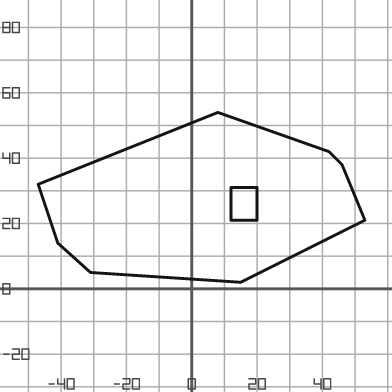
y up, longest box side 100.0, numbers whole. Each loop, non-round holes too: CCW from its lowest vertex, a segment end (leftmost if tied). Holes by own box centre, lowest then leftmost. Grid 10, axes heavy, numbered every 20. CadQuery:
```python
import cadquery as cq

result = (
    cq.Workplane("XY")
    .moveTo(15.0, 2.0)
    .lineTo(53.0, 21.0)
    .lineTo(46.0, 38.0)
    .lineTo(42.0, 42.0)
    .lineTo(8.0, 54.0)
    .lineTo(-47.0, 32.0)
    .lineTo(-41.0, 14.0)
    .lineTo(-31.0, 5.0)
    .close()
    .moveTo(12.0, 21.0)
    .lineTo(20.0, 21.0)
    .lineTo(20.0, 31.0)
    .lineTo(12.0, 31.0)
    .close()
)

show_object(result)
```